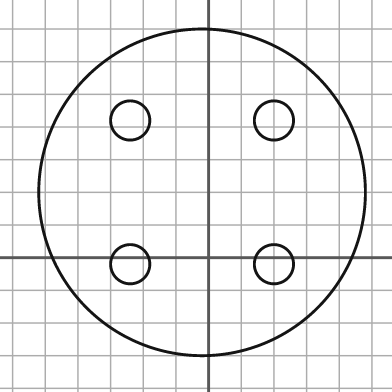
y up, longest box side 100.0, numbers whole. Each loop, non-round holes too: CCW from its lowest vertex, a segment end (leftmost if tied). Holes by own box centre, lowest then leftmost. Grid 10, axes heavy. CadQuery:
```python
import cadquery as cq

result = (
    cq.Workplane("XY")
    .moveTo(-2.0, 20.0)
    .circle(50.0)
    .moveTo(-24.0, -2.0)
    .circle(6.0)
    .moveTo(20.0, -2.0)
    .circle(6.0)
    .moveTo(-24.0, 42.0)
    .circle(6.0)
    .moveTo(20.0, 42.0)
    .circle(6.0)
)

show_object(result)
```